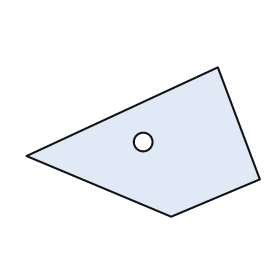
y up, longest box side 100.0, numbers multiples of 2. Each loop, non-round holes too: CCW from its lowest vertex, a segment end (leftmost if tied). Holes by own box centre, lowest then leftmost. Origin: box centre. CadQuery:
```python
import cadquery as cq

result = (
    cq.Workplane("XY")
    .moveTo(12.0, -32.0)
    .lineTo(50.0, -16.0)
    .lineTo(32.0, 32.0)
    .lineTo(-50.0, -6.0)
    .close()
    .moveTo(0.0, 0.0)
    .circle(4.0)
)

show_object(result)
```